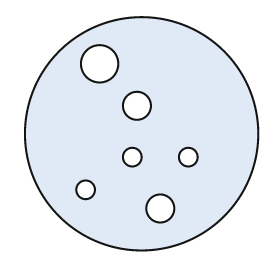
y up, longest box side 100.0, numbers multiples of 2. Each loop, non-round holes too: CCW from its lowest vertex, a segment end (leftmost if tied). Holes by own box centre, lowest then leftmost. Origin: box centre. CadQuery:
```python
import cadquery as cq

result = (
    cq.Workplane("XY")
    .moveTo(0.0, 0.0)
    .circle(50.0)
    .moveTo(8.0, -32.0)
    .circle(6.0)
    .moveTo(-24.0, -24.0)
    .circle(4.0)
    .moveTo(-4.0, -10.0)
    .circle(4.0)
    .moveTo(20.0, -10.0)
    .circle(4.0)
    .moveTo(-2.0, 12.0)
    .circle(6.0)
    .moveTo(-18.0, 30.0)
    .circle(8.0)
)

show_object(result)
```